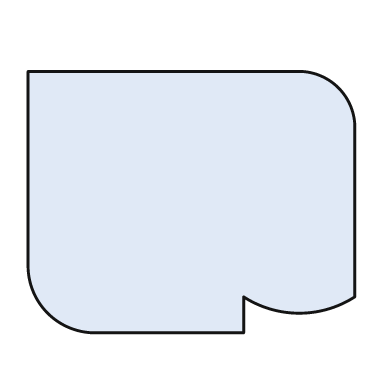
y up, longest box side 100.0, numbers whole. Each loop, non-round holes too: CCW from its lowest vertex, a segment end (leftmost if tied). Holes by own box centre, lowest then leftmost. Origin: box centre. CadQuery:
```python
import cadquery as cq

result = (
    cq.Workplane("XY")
    .moveTo(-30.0, -40.0)
    .lineTo(16.0, -40.0)
    .lineTo(16.0, -29.0)
    .threePointArc((33.0, -34.0), (50.0, -29.0))
    .lineTo(50.0, 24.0)
    .threePointArc((45.0, 35.0), (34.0, 40.0))
    .lineTo(-50.0, 40.0)
    .lineTo(-50.0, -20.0)
    .threePointArc((-44.0, -34.0), (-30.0, -40.0))
    .close()
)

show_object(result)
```